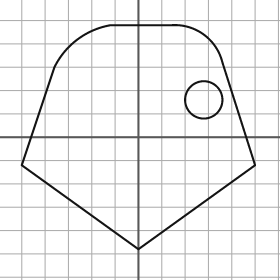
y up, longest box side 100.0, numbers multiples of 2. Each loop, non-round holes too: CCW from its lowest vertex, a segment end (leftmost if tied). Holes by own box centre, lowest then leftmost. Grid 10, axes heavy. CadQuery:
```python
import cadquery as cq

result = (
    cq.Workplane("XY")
    .moveTo(0.0, -48.0)
    .lineTo(50.0, -12.0)
    .lineTo(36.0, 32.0)
    .threePointArc((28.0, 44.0), (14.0, 48.0))
    .lineTo(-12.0, 48.0)
    .threePointArc((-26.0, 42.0), (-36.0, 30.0))
    .lineTo(-50.0, -12.0)
    .close()
    .moveTo(28.0, 16.0)
    .circle(8.0)
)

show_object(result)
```